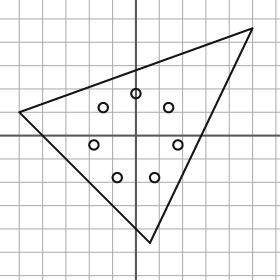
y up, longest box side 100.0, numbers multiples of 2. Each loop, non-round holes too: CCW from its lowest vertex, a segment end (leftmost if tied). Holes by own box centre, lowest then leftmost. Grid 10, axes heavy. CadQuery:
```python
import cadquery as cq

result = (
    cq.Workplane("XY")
    .moveTo(6.0, -46.0)
    .lineTo(50.0, 46.0)
    .lineTo(-50.0, 10.0)
    .close()
    .moveTo(-8.0, -18.0)
    .circle(2.0)
    .moveTo(8.0, -18.0)
    .circle(2.0)
    .moveTo(-18.0, -4.0)
    .circle(2.0)
    .moveTo(18.0, -4.0)
    .circle(2.0)
    .moveTo(-14.0, 12.0)
    .circle(2.0)
    .moveTo(14.0, 12.0)
    .circle(2.0)
    .moveTo(0.0, 18.0)
    .circle(2.0)
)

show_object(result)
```